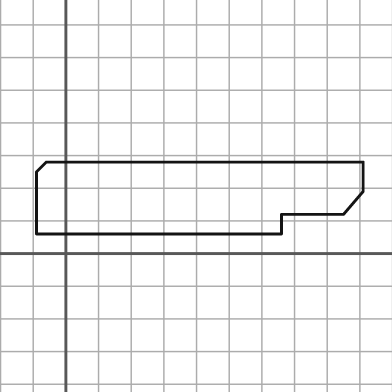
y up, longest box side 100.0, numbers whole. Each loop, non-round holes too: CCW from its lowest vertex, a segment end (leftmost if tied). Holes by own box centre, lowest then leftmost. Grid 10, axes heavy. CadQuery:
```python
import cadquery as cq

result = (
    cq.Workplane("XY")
    .moveTo(-9.0, 6.0)
    .lineTo(66.0, 6.0)
    .lineTo(66.0, 12.0)
    .lineTo(85.0, 12.0)
    .lineTo(91.0, 19.0)
    .lineTo(91.0, 28.0)
    .lineTo(-6.0, 28.0)
    .lineTo(-9.0, 25.0)
    .close()
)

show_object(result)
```